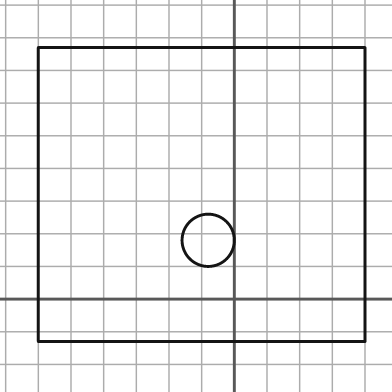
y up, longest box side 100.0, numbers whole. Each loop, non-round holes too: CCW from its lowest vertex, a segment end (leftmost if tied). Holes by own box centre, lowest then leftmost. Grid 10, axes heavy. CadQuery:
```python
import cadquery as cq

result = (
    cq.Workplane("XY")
    .moveTo(-60.0, -13.0)
    .lineTo(40.0, -13.0)
    .lineTo(40.0, 77.0)
    .lineTo(-60.0, 77.0)
    .close()
    .moveTo(-8.0, 18.0)
    .circle(8.0)
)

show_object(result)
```